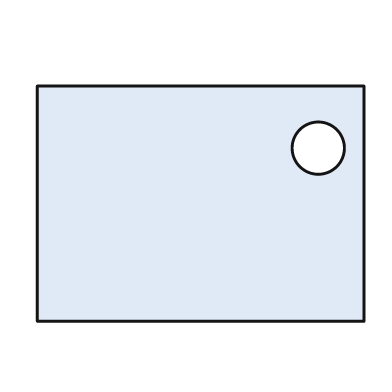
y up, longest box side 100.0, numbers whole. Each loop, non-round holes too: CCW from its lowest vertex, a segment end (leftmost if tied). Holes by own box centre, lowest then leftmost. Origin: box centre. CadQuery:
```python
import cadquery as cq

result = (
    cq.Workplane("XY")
    .moveTo(-50.0, -36.0)
    .lineTo(50.0, -36.0)
    .lineTo(50.0, 36.0)
    .lineTo(-50.0, 36.0)
    .close()
    .moveTo(36.0, 17.0)
    .circle(8.0)
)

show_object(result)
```